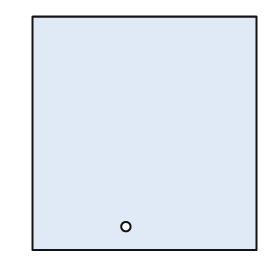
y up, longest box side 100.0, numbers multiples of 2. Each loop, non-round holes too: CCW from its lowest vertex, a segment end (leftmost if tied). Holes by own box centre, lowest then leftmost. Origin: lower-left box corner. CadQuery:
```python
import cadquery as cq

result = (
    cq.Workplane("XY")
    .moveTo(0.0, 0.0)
    .lineTo(96.0, 0.0)
    .lineTo(96.0, 100.0)
    .lineTo(0.0, 100.0)
    .close()
    .moveTo(40.0, 10.0)
    .circle(2.0)
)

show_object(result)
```